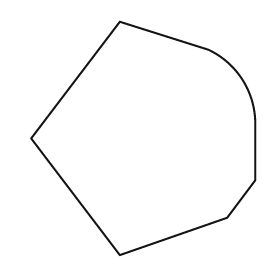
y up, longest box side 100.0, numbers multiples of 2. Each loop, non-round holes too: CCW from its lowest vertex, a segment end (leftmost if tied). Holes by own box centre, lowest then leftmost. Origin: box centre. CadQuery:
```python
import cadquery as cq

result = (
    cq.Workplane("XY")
    .moveTo(-10.0, -50.0)
    .lineTo(36.0, -34.0)
    .lineTo(48.0, -18.0)
    .lineTo(48.0, 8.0)
    .threePointArc((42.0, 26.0), (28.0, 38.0))
    .lineTo(-10.0, 50.0)
    .lineTo(-48.0, 0.0)
    .close()
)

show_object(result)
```